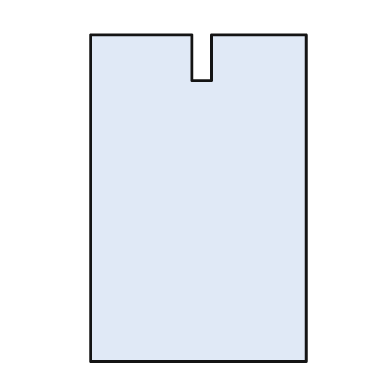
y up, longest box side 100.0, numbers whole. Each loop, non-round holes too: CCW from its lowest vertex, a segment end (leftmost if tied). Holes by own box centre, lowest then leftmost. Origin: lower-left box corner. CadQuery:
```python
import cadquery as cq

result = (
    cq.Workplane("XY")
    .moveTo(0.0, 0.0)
    .lineTo(66.0, 0.0)
    .lineTo(66.0, 100.0)
    .lineTo(37.0, 100.0)
    .lineTo(37.0, 86.0)
    .lineTo(31.0, 86.0)
    .lineTo(31.0, 100.0)
    .lineTo(0.0, 100.0)
    .close()
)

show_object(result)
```